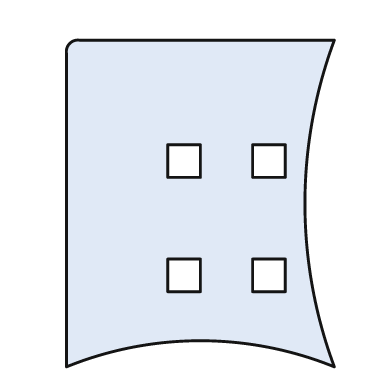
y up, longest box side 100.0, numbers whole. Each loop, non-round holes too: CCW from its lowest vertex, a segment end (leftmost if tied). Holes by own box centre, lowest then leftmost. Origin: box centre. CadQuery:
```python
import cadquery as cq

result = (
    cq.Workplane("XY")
    .moveTo(-41.0, -50.0)
    .threePointArc((0.0, -42.0), (41.0, -50.0))
    .threePointArc((32.0, 0.0), (41.0, 50.0))
    .lineTo(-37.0, 50.0)
    .threePointArc((-40.0, 49.0), (-41.0, 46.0))
    .close()
    .moveTo(-10.0, -27.0)
    .lineTo(0.0, -27.0)
    .lineTo(0.0, -17.0)
    .lineTo(-10.0, -17.0)
    .close()
    .moveTo(16.0, -27.0)
    .lineTo(26.0, -27.0)
    .lineTo(26.0, -17.0)
    .lineTo(16.0, -17.0)
    .close()
    .moveTo(-10.0, 8.0)
    .lineTo(0.0, 8.0)
    .lineTo(0.0, 18.0)
    .lineTo(-10.0, 18.0)
    .close()
    .moveTo(16.0, 8.0)
    .lineTo(26.0, 8.0)
    .lineTo(26.0, 18.0)
    .lineTo(16.0, 18.0)
    .close()
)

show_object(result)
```